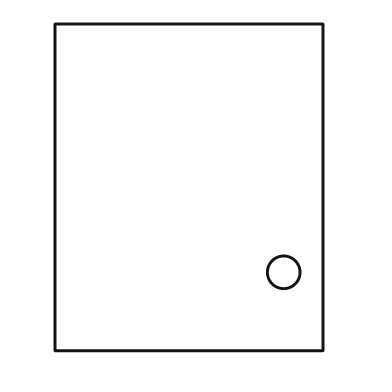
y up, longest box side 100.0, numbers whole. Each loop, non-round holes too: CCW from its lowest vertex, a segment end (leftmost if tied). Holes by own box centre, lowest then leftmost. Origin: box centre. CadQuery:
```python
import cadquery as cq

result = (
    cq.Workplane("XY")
    .moveTo(-41.0, -50.0)
    .lineTo(41.0, -50.0)
    .lineTo(41.0, 50.0)
    .lineTo(-41.0, 50.0)
    .close()
    .moveTo(29.0, -26.0)
    .circle(5.0)
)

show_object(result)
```